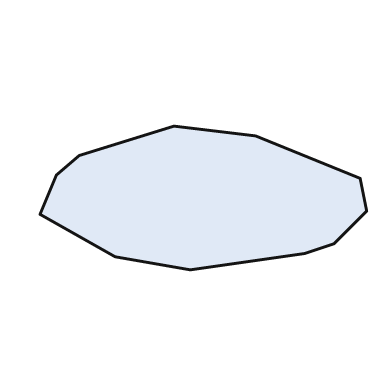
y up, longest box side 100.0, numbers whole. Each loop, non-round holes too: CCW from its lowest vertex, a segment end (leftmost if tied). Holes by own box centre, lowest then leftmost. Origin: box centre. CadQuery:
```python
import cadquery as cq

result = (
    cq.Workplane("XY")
    .moveTo(-4.0, -22.0)
    .lineTo(31.0, -17.0)
    .lineTo(40.0, -14.0)
    .lineTo(50.0, -4.0)
    .lineTo(48.0, 6.0)
    .lineTo(16.0, 19.0)
    .lineTo(-9.0, 22.0)
    .lineTo(-38.0, 13.0)
    .lineTo(-45.0, 7.0)
    .lineTo(-50.0, -5.0)
    .lineTo(-27.0, -18.0)
    .close()
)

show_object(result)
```